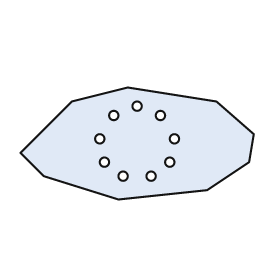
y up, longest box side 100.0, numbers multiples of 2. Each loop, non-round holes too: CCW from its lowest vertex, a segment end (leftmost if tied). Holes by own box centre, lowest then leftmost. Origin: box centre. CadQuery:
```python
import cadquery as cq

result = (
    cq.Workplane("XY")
    .moveTo(-8.0, -24.0)
    .lineTo(30.0, -20.0)
    .lineTo(48.0, -8.0)
    .lineTo(50.0, 4.0)
    .lineTo(34.0, 18.0)
    .lineTo(-4.0, 24.0)
    .lineTo(-28.0, 18.0)
    .lineTo(-50.0, -4.0)
    .lineTo(-40.0, -14.0)
    .close()
    .moveTo(-6.0, -14.0)
    .circle(2.0)
    .moveTo(6.0, -14.0)
    .circle(2.0)
    .moveTo(-14.0, -8.0)
    .circle(2.0)
    .moveTo(14.0, -8.0)
    .circle(2.0)
    .moveTo(-16.0, 2.0)
    .circle(2.0)
    .moveTo(16.0, 2.0)
    .circle(2.0)
    .moveTo(-10.0, 12.0)
    .circle(2.0)
    .moveTo(10.0, 12.0)
    .circle(2.0)
    .moveTo(0.0, 16.0)
    .circle(2.0)
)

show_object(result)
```